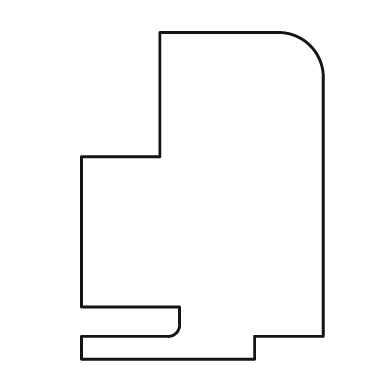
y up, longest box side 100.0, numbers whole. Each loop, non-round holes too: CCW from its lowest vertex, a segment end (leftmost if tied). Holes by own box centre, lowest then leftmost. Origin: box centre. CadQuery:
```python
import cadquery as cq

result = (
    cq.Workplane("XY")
    .moveTo(-37.0, -50.0)
    .lineTo(16.0, -50.0)
    .lineTo(16.0, -43.0)
    .lineTo(37.0, -43.0)
    .lineTo(37.0, 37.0)
    .threePointArc((33.0, 46.0), (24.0, 50.0))
    .lineTo(-13.0, 50.0)
    .lineTo(-13.0, 12.0)
    .lineTo(-37.0, 12.0)
    .lineTo(-37.0, -34.0)
    .lineTo(-7.0, -34.0)
    .lineTo(-7.0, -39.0)
    .threePointArc((-8.0, -42.0), (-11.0, -43.0))
    .lineTo(-37.0, -43.0)
    .close()
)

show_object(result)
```